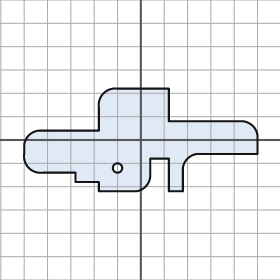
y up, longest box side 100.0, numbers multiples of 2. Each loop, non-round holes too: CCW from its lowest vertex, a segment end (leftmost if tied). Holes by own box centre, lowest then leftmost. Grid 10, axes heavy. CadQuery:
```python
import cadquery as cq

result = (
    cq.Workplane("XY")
    .moveTo(-18.0, -22.0)
    .lineTo(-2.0, -22.0)
    .threePointArc((2.0, -20.0), (4.0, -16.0))
    .lineTo(4.0, -8.0)
    .lineTo(12.0, -8.0)
    .lineTo(12.0, -22.0)
    .lineTo(18.0, -22.0)
    .lineTo(18.0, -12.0)
    .threePointArc((20.0, -8.0), (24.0, -6.0))
    .lineTo(50.0, -6.0)
    .lineTo(50.0, 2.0)
    .threePointArc((48.0, 6.0), (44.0, 8.0))
    .lineTo(12.0, 8.0)
    .lineTo(12.0, 22.0)
    .lineTo(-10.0, 22.0)
    .threePointArc((-16.0, 20.0), (-18.0, 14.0))
    .lineTo(-18.0, 4.0)
    .lineTo(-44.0, 4.0)
    .threePointArc((-48.0, 2.0), (-50.0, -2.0))
    .lineTo(-50.0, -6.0)
    .threePointArc((-48.0, -12.0), (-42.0, -14.0))
    .lineTo(-28.0, -14.0)
    .lineTo(-28.0, -18.0)
    .lineTo(-18.0, -18.0)
    .close()
    .moveTo(-10.0, -12.0)
    .circle(2.0)
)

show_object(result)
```